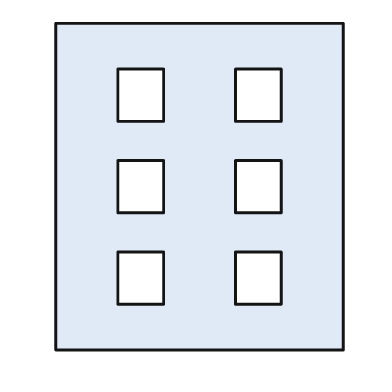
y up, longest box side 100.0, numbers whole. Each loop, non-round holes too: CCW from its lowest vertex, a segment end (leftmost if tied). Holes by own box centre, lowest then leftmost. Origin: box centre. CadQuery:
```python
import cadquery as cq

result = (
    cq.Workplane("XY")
    .moveTo(-44.0, -50.0)
    .lineTo(44.0, -50.0)
    .lineTo(44.0, 50.0)
    .lineTo(-44.0, 50.0)
    .close()
    .moveTo(-25.0, -36.0)
    .lineTo(-11.0, -36.0)
    .lineTo(-11.0, -20.0)
    .lineTo(-25.0, -20.0)
    .close()
    .moveTo(11.0, -36.0)
    .lineTo(25.0, -36.0)
    .lineTo(25.0, -20.0)
    .lineTo(11.0, -20.0)
    .close()
    .moveTo(-25.0, -8.0)
    .lineTo(-11.0, -8.0)
    .lineTo(-11.0, 8.0)
    .lineTo(-25.0, 8.0)
    .close()
    .moveTo(11.0, -8.0)
    .lineTo(25.0, -8.0)
    .lineTo(25.0, 8.0)
    .lineTo(11.0, 8.0)
    .close()
    .moveTo(-25.0, 20.0)
    .lineTo(-11.0, 20.0)
    .lineTo(-11.0, 36.0)
    .lineTo(-25.0, 36.0)
    .close()
    .moveTo(11.0, 20.0)
    .lineTo(25.0, 20.0)
    .lineTo(25.0, 36.0)
    .lineTo(11.0, 36.0)
    .close()
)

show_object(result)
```